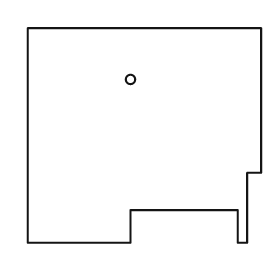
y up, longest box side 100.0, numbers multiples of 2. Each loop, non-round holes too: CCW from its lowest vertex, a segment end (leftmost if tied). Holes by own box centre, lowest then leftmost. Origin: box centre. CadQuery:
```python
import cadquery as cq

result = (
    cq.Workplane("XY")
    .moveTo(-50.0, -46.0)
    .lineTo(-6.0, -46.0)
    .lineTo(-6.0, -32.0)
    .lineTo(40.0, -32.0)
    .lineTo(40.0, -46.0)
    .lineTo(44.0, -46.0)
    .lineTo(44.0, -16.0)
    .lineTo(50.0, -16.0)
    .lineTo(50.0, 46.0)
    .lineTo(-50.0, 46.0)
    .close()
    .moveTo(-6.0, 24.0)
    .circle(2.0)
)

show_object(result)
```